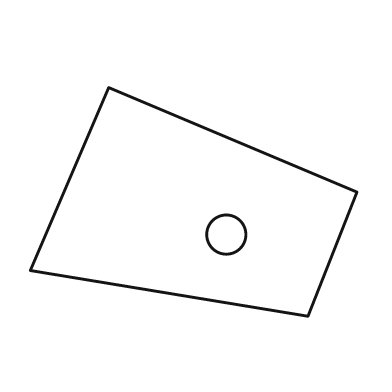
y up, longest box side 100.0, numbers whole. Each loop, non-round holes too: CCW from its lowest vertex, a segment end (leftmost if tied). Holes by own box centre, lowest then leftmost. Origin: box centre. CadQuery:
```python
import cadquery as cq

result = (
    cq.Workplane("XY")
    .moveTo(35.0, -35.0)
    .lineTo(50.0, 3.0)
    .lineTo(-26.0, 35.0)
    .lineTo(-50.0, -21.0)
    .close()
    .moveTo(10.0, -10.0)
    .circle(6.0)
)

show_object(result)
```